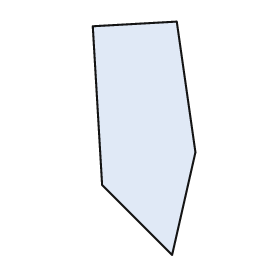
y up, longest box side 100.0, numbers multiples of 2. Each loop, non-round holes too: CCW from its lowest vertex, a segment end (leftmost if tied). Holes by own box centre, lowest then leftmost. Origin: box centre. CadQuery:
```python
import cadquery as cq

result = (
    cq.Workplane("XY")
    .moveTo(12.0, -50.0)
    .lineTo(22.0, -6.0)
    .lineTo(14.0, 50.0)
    .lineTo(-22.0, 48.0)
    .lineTo(-18.0, -20.0)
    .close()
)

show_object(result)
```